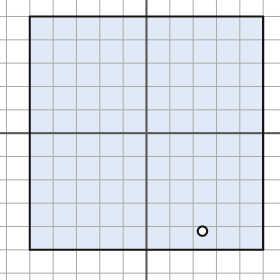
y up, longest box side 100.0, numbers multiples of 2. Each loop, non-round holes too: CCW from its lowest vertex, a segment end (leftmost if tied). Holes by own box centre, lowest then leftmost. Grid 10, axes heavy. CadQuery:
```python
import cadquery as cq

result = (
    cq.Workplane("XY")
    .moveTo(-50.0, -50.0)
    .lineTo(50.0, -50.0)
    .lineTo(50.0, 50.0)
    .lineTo(-50.0, 50.0)
    .close()
    .moveTo(24.0, -42.0)
    .circle(2.0)
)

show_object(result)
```